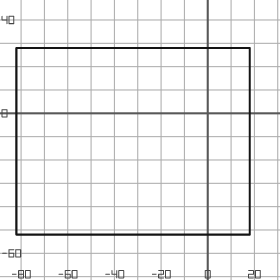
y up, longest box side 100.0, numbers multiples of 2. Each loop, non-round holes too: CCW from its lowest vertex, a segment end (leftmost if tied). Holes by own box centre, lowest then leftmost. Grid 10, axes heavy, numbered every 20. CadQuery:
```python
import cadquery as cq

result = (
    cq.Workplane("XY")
    .moveTo(-82.0, -52.0)
    .lineTo(18.0, -52.0)
    .lineTo(18.0, 28.0)
    .lineTo(-82.0, 28.0)
    .close()
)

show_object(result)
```